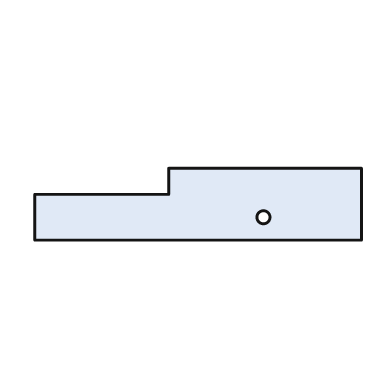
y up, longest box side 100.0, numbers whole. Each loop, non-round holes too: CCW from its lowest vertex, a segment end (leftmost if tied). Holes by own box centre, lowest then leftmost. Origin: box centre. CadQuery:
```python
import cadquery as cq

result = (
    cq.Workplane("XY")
    .moveTo(-50.0, -11.0)
    .lineTo(50.0, -11.0)
    .lineTo(50.0, 11.0)
    .lineTo(-9.0, 11.0)
    .lineTo(-9.0, 3.0)
    .lineTo(-50.0, 3.0)
    .close()
    .moveTo(20.0, -4.0)
    .circle(2.0)
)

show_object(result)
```